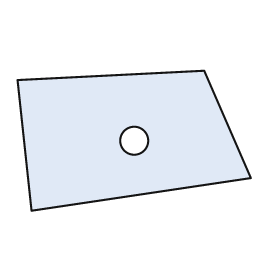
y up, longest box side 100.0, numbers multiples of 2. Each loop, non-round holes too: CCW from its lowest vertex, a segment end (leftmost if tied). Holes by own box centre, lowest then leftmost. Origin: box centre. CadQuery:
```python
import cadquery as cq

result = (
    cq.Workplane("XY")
    .moveTo(-44.0, -30.0)
    .lineTo(50.0, -16.0)
    .lineTo(30.0, 30.0)
    .lineTo(-50.0, 26.0)
    .close()
    .moveTo(0.0, 0.0)
    .circle(6.0)
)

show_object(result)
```